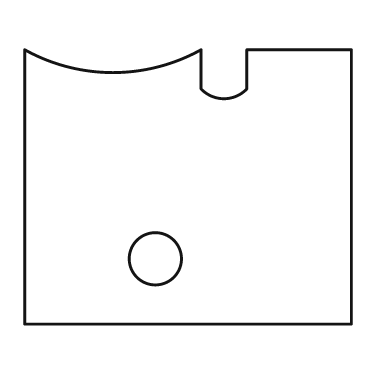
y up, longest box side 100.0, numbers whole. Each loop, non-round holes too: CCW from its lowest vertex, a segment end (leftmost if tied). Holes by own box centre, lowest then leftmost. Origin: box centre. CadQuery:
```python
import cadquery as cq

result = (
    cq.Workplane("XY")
    .moveTo(-50.0, -42.0)
    .lineTo(50.0, -42.0)
    .lineTo(50.0, 42.0)
    .lineTo(18.0, 42.0)
    .lineTo(18.0, 30.0)
    .threePointArc((11.0, 27.0), (4.0, 30.0))
    .lineTo(4.0, 42.0)
    .threePointArc((-23.0, 35.0), (-50.0, 42.0))
    .close()
    .moveTo(-10.0, -22.0)
    .circle(8.0)
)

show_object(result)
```